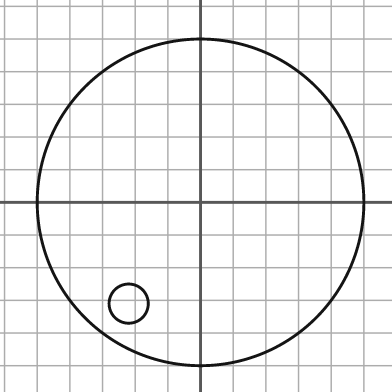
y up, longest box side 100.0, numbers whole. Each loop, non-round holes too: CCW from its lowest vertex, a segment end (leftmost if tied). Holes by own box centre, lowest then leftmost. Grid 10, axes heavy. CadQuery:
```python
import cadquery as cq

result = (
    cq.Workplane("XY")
    .moveTo(0.0, 0.0)
    .circle(50.0)
    .moveTo(-22.0, -31.0)
    .circle(6.0)
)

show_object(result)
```